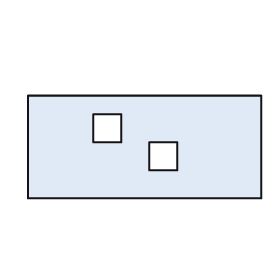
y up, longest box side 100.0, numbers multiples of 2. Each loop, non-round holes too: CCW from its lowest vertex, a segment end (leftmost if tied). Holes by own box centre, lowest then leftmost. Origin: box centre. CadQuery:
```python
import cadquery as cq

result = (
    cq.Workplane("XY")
    .moveTo(-50.0, -22.0)
    .lineTo(50.0, -22.0)
    .lineTo(50.0, 22.0)
    .lineTo(-50.0, 22.0)
    .close()
    .moveTo(2.0, -10.0)
    .lineTo(14.0, -10.0)
    .lineTo(14.0, 2.0)
    .lineTo(2.0, 2.0)
    .close()
    .moveTo(-22.0, 2.0)
    .lineTo(-10.0, 2.0)
    .lineTo(-10.0, 14.0)
    .lineTo(-22.0, 14.0)
    .close()
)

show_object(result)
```